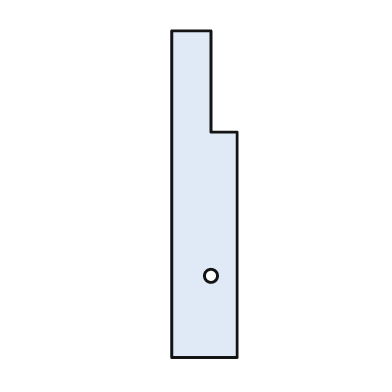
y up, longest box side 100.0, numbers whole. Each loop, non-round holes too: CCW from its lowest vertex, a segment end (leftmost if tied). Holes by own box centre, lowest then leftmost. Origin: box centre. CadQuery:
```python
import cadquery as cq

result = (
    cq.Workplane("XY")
    .moveTo(-10.0, -50.0)
    .lineTo(10.0, -50.0)
    .lineTo(10.0, 19.0)
    .lineTo(2.0, 19.0)
    .lineTo(2.0, 50.0)
    .lineTo(-10.0, 50.0)
    .close()
    .moveTo(2.0, -25.0)
    .circle(2.0)
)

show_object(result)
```